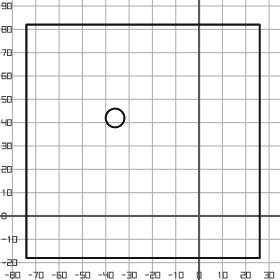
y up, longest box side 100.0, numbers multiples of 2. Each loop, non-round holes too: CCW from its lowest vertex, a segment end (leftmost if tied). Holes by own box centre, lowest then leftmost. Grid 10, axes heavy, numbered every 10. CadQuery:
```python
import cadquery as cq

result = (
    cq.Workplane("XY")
    .moveTo(-74.0, -18.0)
    .lineTo(26.0, -18.0)
    .lineTo(26.0, 82.0)
    .lineTo(-74.0, 82.0)
    .close()
    .moveTo(-36.0, 42.0)
    .circle(4.0)
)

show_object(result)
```